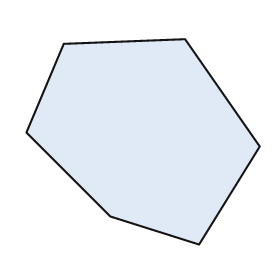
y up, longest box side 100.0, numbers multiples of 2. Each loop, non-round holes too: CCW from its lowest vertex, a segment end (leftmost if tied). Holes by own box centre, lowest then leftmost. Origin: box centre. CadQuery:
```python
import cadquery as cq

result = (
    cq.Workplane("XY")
    .moveTo(24.0, -44.0)
    .lineTo(50.0, -2.0)
    .lineTo(18.0, 44.0)
    .lineTo(-34.0, 42.0)
    .lineTo(-50.0, 4.0)
    .lineTo(-14.0, -32.0)
    .close()
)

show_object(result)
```